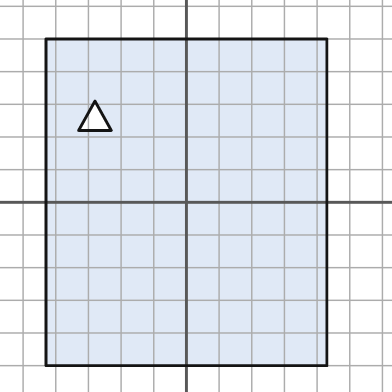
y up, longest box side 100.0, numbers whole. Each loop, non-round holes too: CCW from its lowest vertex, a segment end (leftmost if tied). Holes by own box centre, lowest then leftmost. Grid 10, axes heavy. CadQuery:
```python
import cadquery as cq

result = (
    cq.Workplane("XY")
    .moveTo(-43.0, -50.0)
    .lineTo(43.0, -50.0)
    .lineTo(43.0, 50.0)
    .lineTo(-43.0, 50.0)
    .close()
    .moveTo(-33.0, 22.0)
    .lineTo(-23.0, 22.0)
    .lineTo(-28.0, 31.0)
    .close()
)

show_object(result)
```